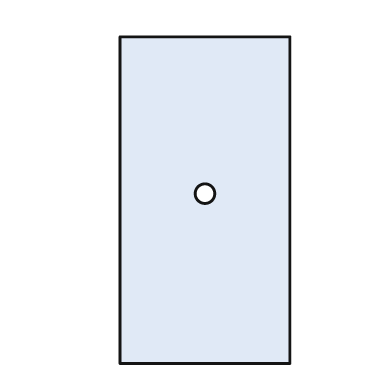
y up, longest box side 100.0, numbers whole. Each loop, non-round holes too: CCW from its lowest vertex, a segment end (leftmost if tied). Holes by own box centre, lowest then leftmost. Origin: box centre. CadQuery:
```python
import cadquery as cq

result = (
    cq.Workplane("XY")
    .moveTo(-26.0, -50.0)
    .lineTo(26.0, -50.0)
    .lineTo(26.0, 50.0)
    .lineTo(-26.0, 50.0)
    .close()
    .moveTo(0.0, 2.0)
    .circle(3.0)
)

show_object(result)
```